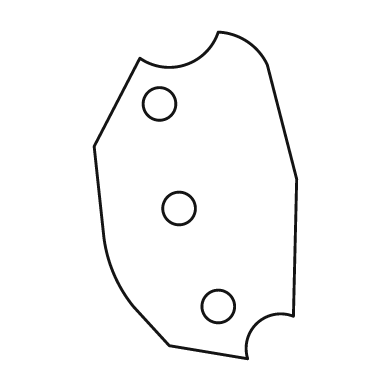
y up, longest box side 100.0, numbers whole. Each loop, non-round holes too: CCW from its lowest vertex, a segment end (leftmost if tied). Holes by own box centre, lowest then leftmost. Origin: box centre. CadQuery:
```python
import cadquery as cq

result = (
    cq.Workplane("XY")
    .moveTo(16.0, -50.0)
    .threePointArc((19.0, -39.0), (30.0, -37.0))
    .lineTo(31.0, 5.0)
    .lineTo(22.0, 40.0)
    .threePointArc((16.0, 47.0), (7.0, 50.0))
    .threePointArc((-3.0, 40.0), (-17.0, 42.0))
    .lineTo(-31.0, 15.0)
    .lineTo(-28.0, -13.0)
    .threePointArc((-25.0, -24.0), (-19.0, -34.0))
    .lineTo(-8.0, -46.0)
    .close()
    .moveTo(7.0, -34.0)
    .circle(5.0)
    .moveTo(-5.0, -4.0)
    .circle(5.0)
    .moveTo(-11.0, 28.0)
    .circle(5.0)
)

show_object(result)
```